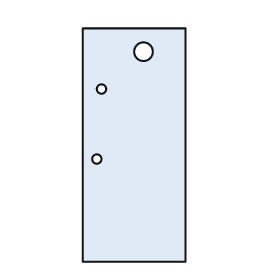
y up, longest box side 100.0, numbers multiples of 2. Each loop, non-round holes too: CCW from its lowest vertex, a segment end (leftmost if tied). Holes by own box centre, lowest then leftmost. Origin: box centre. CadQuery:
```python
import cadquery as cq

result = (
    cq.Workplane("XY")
    .moveTo(-22.0, -50.0)
    .lineTo(22.0, -50.0)
    .lineTo(22.0, 50.0)
    .lineTo(-22.0, 50.0)
    .close()
    .moveTo(-16.0, -6.0)
    .circle(2.0)
    .moveTo(-14.0, 24.0)
    .circle(2.0)
    .moveTo(4.0, 40.0)
    .circle(4.0)
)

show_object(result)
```